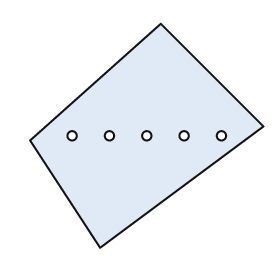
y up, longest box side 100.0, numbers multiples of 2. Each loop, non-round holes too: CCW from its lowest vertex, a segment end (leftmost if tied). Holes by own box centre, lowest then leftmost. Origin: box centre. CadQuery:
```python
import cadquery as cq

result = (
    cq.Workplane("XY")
    .moveTo(-20.0, -48.0)
    .lineTo(50.0, 4.0)
    .lineTo(6.0, 48.0)
    .lineTo(-50.0, -2.0)
    .close()
    .moveTo(-32.0, 0.0)
    .circle(2.0)
    .moveTo(-16.0, 0.0)
    .circle(2.0)
    .moveTo(0.0, 0.0)
    .circle(2.0)
    .moveTo(16.0, 0.0)
    .circle(2.0)
    .moveTo(32.0, 0.0)
    .circle(2.0)
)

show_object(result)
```